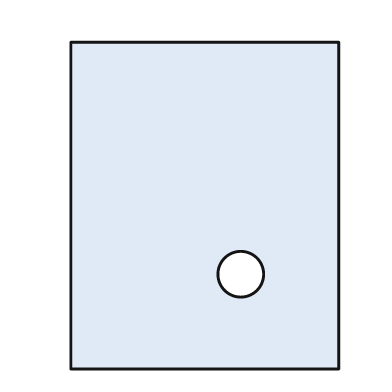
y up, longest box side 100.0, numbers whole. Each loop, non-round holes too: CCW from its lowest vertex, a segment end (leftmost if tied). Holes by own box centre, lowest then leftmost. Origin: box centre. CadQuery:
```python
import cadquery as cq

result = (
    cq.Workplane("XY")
    .moveTo(-41.0, -50.0)
    .lineTo(41.0, -50.0)
    .lineTo(41.0, 50.0)
    .lineTo(-41.0, 50.0)
    .close()
    .moveTo(11.0, -21.0)
    .circle(7.0)
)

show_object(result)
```